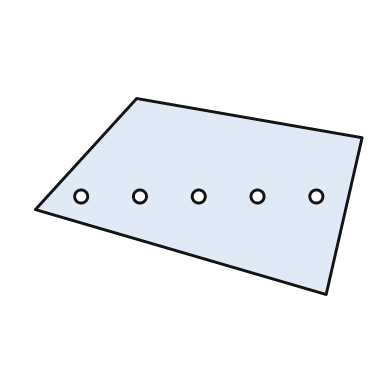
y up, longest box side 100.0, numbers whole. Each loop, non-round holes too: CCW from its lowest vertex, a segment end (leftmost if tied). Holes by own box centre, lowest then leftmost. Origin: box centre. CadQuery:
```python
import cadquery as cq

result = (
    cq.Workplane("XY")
    .moveTo(39.0, -30.0)
    .lineTo(50.0, 18.0)
    .lineTo(-19.0, 30.0)
    .lineTo(-50.0, -4.0)
    .close()
    .moveTo(-36.0, 0.0)
    .circle(2.0)
    .moveTo(-18.0, 0.0)
    .circle(2.0)
    .moveTo(0.0, 0.0)
    .circle(2.0)
    .moveTo(18.0, 0.0)
    .circle(2.0)
    .moveTo(36.0, 0.0)
    .circle(2.0)
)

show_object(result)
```